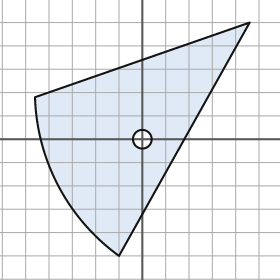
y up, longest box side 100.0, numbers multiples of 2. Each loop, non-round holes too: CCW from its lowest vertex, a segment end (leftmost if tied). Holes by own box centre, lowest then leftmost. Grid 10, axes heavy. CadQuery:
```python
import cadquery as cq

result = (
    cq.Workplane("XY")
    .moveTo(-10.0, -50.0)
    .lineTo(46.0, 50.0)
    .lineTo(-46.0, 18.0)
    .threePointArc((-36.0, -20.0), (-10.0, -50.0))
    .close()
    .moveTo(0.0, 0.0)
    .circle(4.0)
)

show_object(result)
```